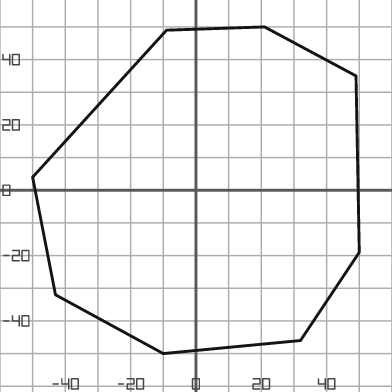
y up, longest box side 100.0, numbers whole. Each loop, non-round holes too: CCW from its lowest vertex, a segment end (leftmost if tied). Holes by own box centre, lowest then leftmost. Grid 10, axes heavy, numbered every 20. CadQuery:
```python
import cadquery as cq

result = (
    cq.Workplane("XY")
    .moveTo(-10.0, -50.0)
    .lineTo(32.0, -46.0)
    .lineTo(50.0, -19.0)
    .lineTo(49.0, 35.0)
    .lineTo(21.0, 50.0)
    .lineTo(-9.0, 49.0)
    .lineTo(-50.0, 4.0)
    .lineTo(-43.0, -32.0)
    .close()
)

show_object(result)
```